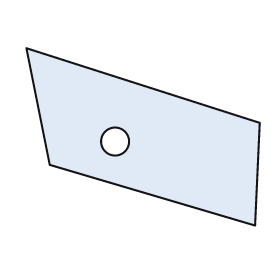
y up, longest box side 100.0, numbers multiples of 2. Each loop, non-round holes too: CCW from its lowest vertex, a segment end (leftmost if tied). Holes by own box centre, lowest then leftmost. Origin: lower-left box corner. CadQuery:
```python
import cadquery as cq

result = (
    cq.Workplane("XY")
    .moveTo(98.0, 0.0)
    .lineTo(100.0, 44.0)
    .lineTo(0.0, 76.0)
    .lineTo(10.0, 26.0)
    .close()
    .moveTo(38.0, 36.0)
    .circle(6.0)
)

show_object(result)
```